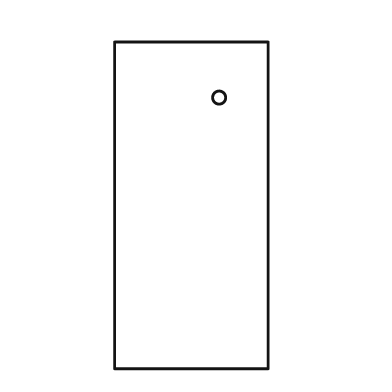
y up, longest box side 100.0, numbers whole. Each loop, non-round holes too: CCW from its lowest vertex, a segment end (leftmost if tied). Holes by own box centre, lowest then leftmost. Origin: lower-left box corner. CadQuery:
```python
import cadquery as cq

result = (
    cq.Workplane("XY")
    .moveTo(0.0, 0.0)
    .lineTo(47.0, 0.0)
    .lineTo(47.0, 100.0)
    .lineTo(0.0, 100.0)
    .close()
    .moveTo(32.0, 83.0)
    .circle(2.0)
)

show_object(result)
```